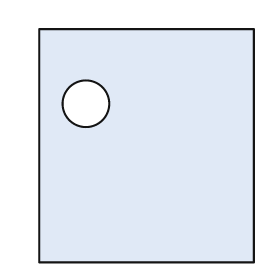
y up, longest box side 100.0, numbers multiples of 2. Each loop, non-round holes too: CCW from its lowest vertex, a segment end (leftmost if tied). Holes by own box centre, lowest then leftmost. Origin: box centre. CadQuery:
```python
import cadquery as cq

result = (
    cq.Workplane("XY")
    .moveTo(-46.0, -50.0)
    .lineTo(46.0, -50.0)
    .lineTo(46.0, 50.0)
    .lineTo(-46.0, 50.0)
    .close()
    .moveTo(-26.0, 18.0)
    .circle(10.0)
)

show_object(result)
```